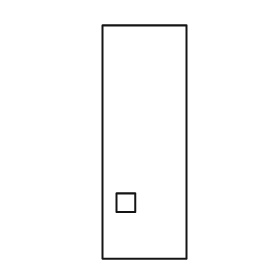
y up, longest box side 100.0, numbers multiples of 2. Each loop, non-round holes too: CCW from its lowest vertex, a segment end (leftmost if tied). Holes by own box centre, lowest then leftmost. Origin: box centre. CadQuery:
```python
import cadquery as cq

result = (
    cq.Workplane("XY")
    .moveTo(-18.0, -50.0)
    .lineTo(18.0, -50.0)
    .lineTo(18.0, 50.0)
    .lineTo(-18.0, 50.0)
    .close()
    .moveTo(-12.0, -30.0)
    .lineTo(-4.0, -30.0)
    .lineTo(-4.0, -22.0)
    .lineTo(-12.0, -22.0)
    .close()
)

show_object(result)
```